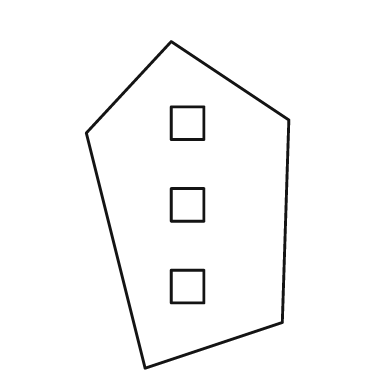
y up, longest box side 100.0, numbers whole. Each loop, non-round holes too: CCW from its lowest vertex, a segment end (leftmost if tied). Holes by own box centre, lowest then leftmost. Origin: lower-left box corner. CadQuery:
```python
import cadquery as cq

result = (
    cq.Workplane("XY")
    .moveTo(18.0, 0.0)
    .lineTo(60.0, 14.0)
    .lineTo(62.0, 76.0)
    .lineTo(26.0, 100.0)
    .lineTo(0.0, 72.0)
    .close()
    .moveTo(26.0, 20.0)
    .lineTo(36.0, 20.0)
    .lineTo(36.0, 30.0)
    .lineTo(26.0, 30.0)
    .close()
    .moveTo(26.0, 45.0)
    .lineTo(36.0, 45.0)
    .lineTo(36.0, 55.0)
    .lineTo(26.0, 55.0)
    .close()
    .moveTo(26.0, 70.0)
    .lineTo(36.0, 70.0)
    .lineTo(36.0, 80.0)
    .lineTo(26.0, 80.0)
    .close()
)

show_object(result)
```